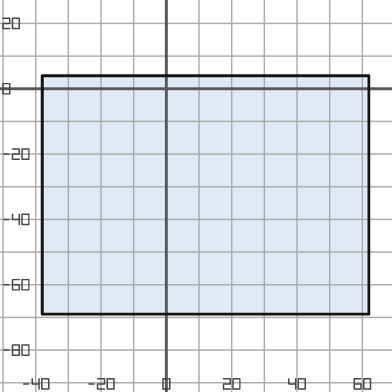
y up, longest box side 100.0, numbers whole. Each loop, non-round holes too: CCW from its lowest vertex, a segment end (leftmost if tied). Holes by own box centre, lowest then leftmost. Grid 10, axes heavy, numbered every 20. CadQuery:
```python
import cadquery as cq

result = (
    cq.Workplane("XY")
    .moveTo(-38.0, -69.0)
    .lineTo(62.0, -69.0)
    .lineTo(62.0, 4.0)
    .lineTo(-38.0, 4.0)
    .close()
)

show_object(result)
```